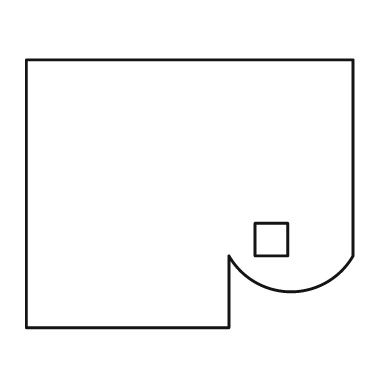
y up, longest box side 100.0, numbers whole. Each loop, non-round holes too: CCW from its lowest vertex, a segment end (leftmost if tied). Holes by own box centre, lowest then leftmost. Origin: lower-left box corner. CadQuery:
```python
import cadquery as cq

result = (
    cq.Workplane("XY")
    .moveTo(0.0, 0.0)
    .lineTo(62.0, 0.0)
    .lineTo(62.0, 22.0)
    .threePointArc((81.0, 11.0), (100.0, 22.0))
    .lineTo(100.0, 82.0)
    .lineTo(0.0, 82.0)
    .close()
    .moveTo(70.0, 22.0)
    .lineTo(80.0, 22.0)
    .lineTo(80.0, 32.0)
    .lineTo(70.0, 32.0)
    .close()
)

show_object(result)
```